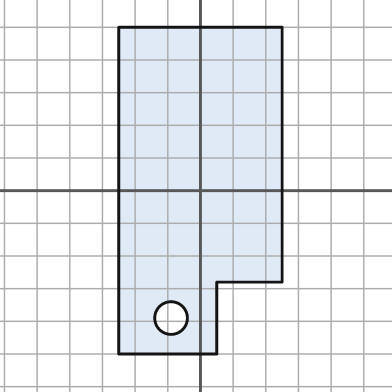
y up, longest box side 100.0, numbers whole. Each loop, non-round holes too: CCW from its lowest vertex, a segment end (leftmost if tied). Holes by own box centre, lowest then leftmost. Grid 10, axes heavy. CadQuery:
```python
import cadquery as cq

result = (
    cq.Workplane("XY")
    .moveTo(-25.0, -50.0)
    .lineTo(5.0, -50.0)
    .lineTo(5.0, -28.0)
    .lineTo(25.0, -28.0)
    .lineTo(25.0, 50.0)
    .lineTo(-25.0, 50.0)
    .close()
    .moveTo(-9.0, -39.0)
    .circle(5.0)
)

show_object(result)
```